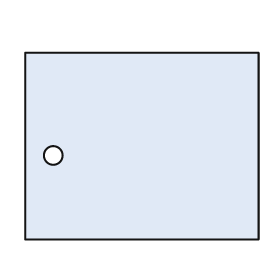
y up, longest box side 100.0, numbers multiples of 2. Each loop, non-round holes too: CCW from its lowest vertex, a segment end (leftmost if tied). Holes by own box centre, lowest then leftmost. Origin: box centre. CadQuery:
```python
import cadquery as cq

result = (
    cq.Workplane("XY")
    .moveTo(-50.0, -40.0)
    .lineTo(50.0, -40.0)
    .lineTo(50.0, 40.0)
    .lineTo(-50.0, 40.0)
    .close()
    .moveTo(-38.0, -4.0)
    .circle(4.0)
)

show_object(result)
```